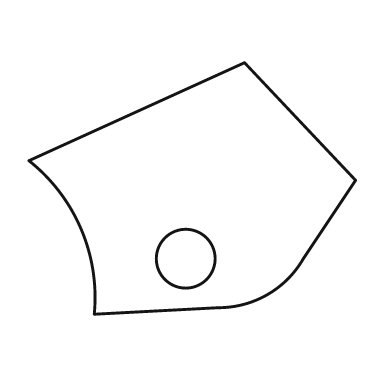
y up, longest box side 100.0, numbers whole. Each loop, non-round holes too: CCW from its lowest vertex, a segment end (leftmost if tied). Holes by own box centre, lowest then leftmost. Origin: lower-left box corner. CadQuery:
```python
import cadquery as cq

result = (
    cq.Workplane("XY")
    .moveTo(20.0, 0.0)
    .lineTo(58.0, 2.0)
    .threePointArc((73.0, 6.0), (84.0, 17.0))
    .lineTo(100.0, 41.0)
    .lineTo(66.0, 77.0)
    .lineTo(0.0, 47.0)
    .threePointArc((16.0, 26.0), (20.0, 0.0))
    .close()
    .moveTo(48.0, 17.0)
    .circle(9.0)
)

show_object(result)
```